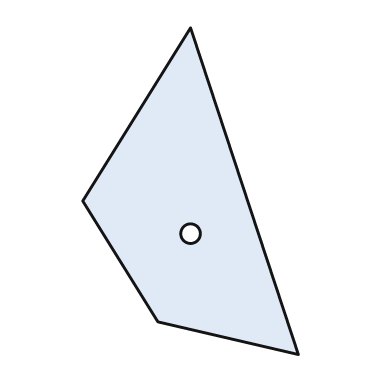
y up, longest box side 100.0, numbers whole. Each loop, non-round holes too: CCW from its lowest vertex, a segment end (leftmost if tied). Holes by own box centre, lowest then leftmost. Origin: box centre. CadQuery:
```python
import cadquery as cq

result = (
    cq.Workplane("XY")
    .moveTo(33.0, -50.0)
    .lineTo(0.0, 50.0)
    .lineTo(-33.0, -3.0)
    .lineTo(-10.0, -40.0)
    .close()
    .moveTo(0.0, -13.0)
    .circle(3.0)
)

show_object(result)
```